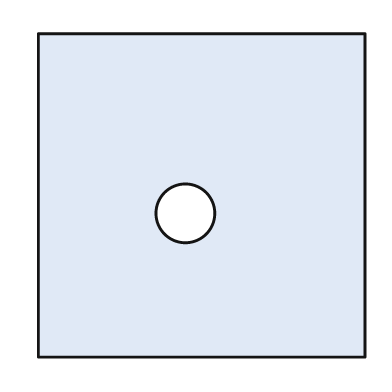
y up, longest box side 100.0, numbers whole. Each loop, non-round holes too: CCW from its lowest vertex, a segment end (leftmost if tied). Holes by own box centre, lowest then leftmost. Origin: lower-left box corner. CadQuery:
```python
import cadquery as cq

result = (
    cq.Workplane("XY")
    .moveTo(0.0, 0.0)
    .lineTo(100.0, 0.0)
    .lineTo(100.0, 99.0)
    .lineTo(0.0, 99.0)
    .close()
    .moveTo(45.0, 44.0)
    .circle(9.0)
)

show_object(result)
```